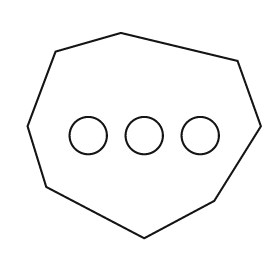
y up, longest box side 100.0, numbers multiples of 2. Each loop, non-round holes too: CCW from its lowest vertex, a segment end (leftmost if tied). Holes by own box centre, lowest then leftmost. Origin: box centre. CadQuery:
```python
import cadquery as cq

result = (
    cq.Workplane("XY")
    .moveTo(0.0, -44.0)
    .lineTo(30.0, -28.0)
    .lineTo(50.0, 4.0)
    .lineTo(40.0, 32.0)
    .lineTo(-10.0, 44.0)
    .lineTo(-38.0, 36.0)
    .lineTo(-50.0, 4.0)
    .lineTo(-42.0, -22.0)
    .close()
    .moveTo(-24.0, 0.0)
    .circle(8.0)
    .moveTo(0.0, 0.0)
    .circle(8.0)
    .moveTo(24.0, 0.0)
    .circle(8.0)
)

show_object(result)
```